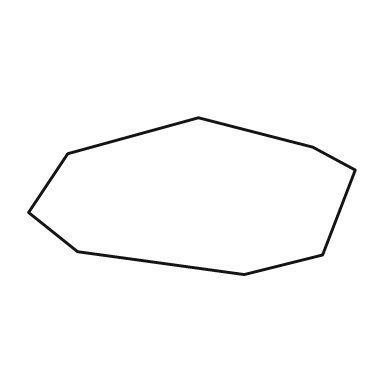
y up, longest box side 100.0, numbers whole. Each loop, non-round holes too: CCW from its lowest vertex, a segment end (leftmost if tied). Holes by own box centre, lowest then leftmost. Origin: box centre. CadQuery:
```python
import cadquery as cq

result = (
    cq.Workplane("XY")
    .moveTo(16.0, -24.0)
    .lineTo(40.0, -18.0)
    .lineTo(50.0, 8.0)
    .lineTo(37.0, 15.0)
    .lineTo(2.0, 24.0)
    .lineTo(-38.0, 13.0)
    .lineTo(-50.0, -5.0)
    .lineTo(-35.0, -17.0)
    .close()
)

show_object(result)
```